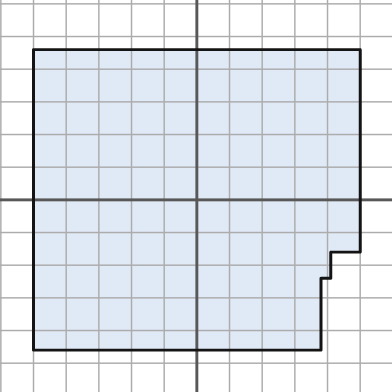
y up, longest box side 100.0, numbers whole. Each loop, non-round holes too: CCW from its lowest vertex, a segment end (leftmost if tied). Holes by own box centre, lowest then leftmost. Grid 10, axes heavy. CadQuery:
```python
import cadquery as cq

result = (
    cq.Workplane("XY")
    .moveTo(-50.0, -46.0)
    .lineTo(38.0, -46.0)
    .lineTo(38.0, -24.0)
    .lineTo(41.0, -24.0)
    .lineTo(41.0, -16.0)
    .lineTo(50.0, -16.0)
    .lineTo(50.0, 46.0)
    .lineTo(-50.0, 46.0)
    .close()
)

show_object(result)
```